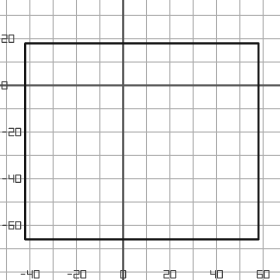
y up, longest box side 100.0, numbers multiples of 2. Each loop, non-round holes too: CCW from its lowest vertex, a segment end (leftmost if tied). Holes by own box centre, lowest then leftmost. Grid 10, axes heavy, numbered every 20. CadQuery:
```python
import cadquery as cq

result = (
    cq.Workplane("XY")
    .moveTo(-42.0, -66.0)
    .lineTo(58.0, -66.0)
    .lineTo(58.0, 18.0)
    .lineTo(-42.0, 18.0)
    .close()
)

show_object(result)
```